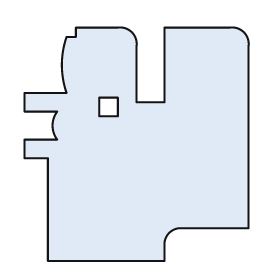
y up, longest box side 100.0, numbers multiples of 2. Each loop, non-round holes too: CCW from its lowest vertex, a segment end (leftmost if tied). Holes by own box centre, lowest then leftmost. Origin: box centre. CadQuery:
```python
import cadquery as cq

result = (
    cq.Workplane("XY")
    .moveTo(-38.0, -50.0)
    .lineTo(12.0, -50.0)
    .lineTo(12.0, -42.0)
    .threePointArc((14.0, -38.0), (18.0, -36.0))
    .lineTo(48.0, -36.0)
    .lineTo(48.0, 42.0)
    .threePointArc((46.0, 48.0), (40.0, 50.0))
    .lineTo(12.0, 50.0)
    .lineTo(12.0, 18.0)
    .lineTo(0.0, 18.0)
    .lineTo(0.0, 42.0)
    .threePointArc((-2.0, 48.0), (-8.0, 50.0))
    .lineTo(-26.0, 50.0)
    .lineTo(-26.0, 46.0)
    .lineTo(-30.0, 46.0)
    .threePointArc((-32.0, 34.0), (-30.0, 22.0))
    .lineTo(-48.0, 22.0)
    .lineTo(-48.0, 14.0)
    .lineTo(-34.0, 14.0)
    .threePointArc((-36.0, 8.0), (-34.0, 2.0))
    .lineTo(-48.0, 2.0)
    .lineTo(-48.0, -6.0)
    .lineTo(-38.0, -6.0)
    .close()
    .moveTo(-16.0, 12.0)
    .lineTo(-8.0, 12.0)
    .lineTo(-8.0, 20.0)
    .lineTo(-16.0, 20.0)
    .close()
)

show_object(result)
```